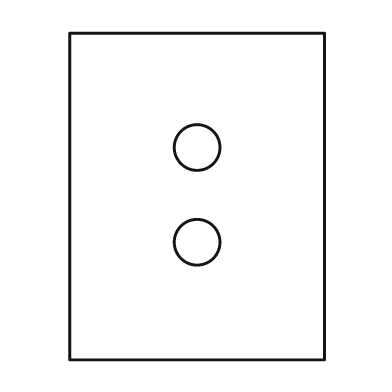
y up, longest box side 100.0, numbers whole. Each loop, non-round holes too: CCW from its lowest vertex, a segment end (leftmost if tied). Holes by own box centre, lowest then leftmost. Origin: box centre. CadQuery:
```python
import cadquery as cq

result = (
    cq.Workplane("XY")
    .moveTo(-39.0, -50.0)
    .lineTo(39.0, -50.0)
    .lineTo(39.0, 50.0)
    .lineTo(-39.0, 50.0)
    .close()
    .moveTo(0.0, -14.0)
    .circle(7.0)
    .moveTo(0.0, 15.0)
    .circle(7.0)
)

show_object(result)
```